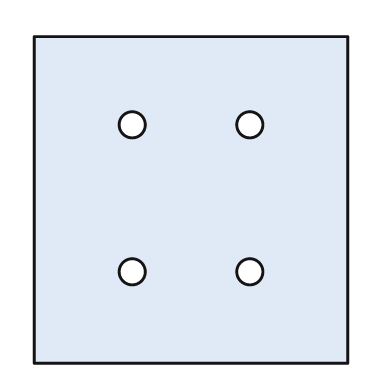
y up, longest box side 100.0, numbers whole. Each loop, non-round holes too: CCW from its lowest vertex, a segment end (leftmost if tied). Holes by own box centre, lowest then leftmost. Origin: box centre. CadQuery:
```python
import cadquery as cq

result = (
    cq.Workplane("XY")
    .moveTo(-48.0, -50.0)
    .lineTo(48.0, -50.0)
    .lineTo(48.0, 50.0)
    .lineTo(-48.0, 50.0)
    .close()
    .moveTo(-18.0, -22.0)
    .circle(4.0)
    .moveTo(18.0, -22.0)
    .circle(4.0)
    .moveTo(-18.0, 23.0)
    .circle(4.0)
    .moveTo(18.0, 23.0)
    .circle(4.0)
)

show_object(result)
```